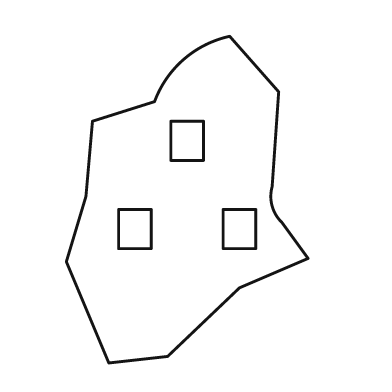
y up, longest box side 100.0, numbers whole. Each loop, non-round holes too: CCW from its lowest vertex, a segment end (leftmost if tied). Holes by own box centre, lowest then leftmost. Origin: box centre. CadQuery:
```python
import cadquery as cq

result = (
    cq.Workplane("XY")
    .moveTo(-24.0, -50.0)
    .lineTo(-6.0, -48.0)
    .lineTo(16.0, -27.0)
    .lineTo(37.0, -18.0)
    .lineTo(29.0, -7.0)
    .threePointArc((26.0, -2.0), (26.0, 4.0))
    .lineTo(28.0, 33.0)
    .lineTo(13.0, 50.0)
    .threePointArc((-1.0, 43.0), (-10.0, 30.0))
    .lineTo(-29.0, 24.0)
    .lineTo(-31.0, 1.0)
    .lineTo(-37.0, -19.0)
    .close()
    .moveTo(-21.0, -15.0)
    .lineTo(-11.0, -15.0)
    .lineTo(-11.0, -3.0)
    .lineTo(-21.0, -3.0)
    .close()
    .moveTo(11.0, -15.0)
    .lineTo(21.0, -15.0)
    .lineTo(21.0, -3.0)
    .lineTo(11.0, -3.0)
    .close()
    .moveTo(-5.0, 12.0)
    .lineTo(5.0, 12.0)
    .lineTo(5.0, 24.0)
    .lineTo(-5.0, 24.0)
    .close()
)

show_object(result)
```